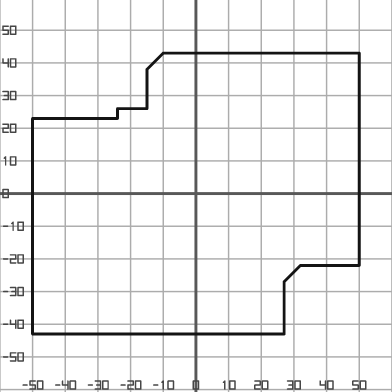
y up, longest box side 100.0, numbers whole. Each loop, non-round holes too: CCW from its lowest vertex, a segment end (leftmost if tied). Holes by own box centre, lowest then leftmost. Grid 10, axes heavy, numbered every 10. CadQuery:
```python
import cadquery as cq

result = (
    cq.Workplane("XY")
    .moveTo(-50.0, -43.0)
    .lineTo(27.0, -43.0)
    .lineTo(27.0, -27.0)
    .lineTo(32.0, -22.0)
    .lineTo(50.0, -22.0)
    .lineTo(50.0, 43.0)
    .lineTo(-10.0, 43.0)
    .lineTo(-15.0, 38.0)
    .lineTo(-15.0, 26.0)
    .lineTo(-24.0, 26.0)
    .lineTo(-24.0, 23.0)
    .lineTo(-50.0, 23.0)
    .close()
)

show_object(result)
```